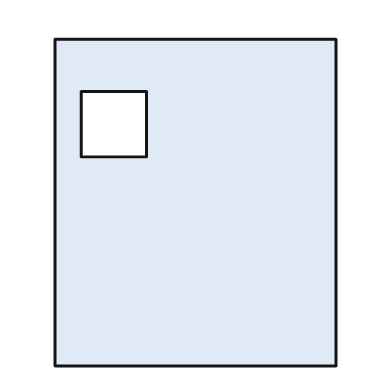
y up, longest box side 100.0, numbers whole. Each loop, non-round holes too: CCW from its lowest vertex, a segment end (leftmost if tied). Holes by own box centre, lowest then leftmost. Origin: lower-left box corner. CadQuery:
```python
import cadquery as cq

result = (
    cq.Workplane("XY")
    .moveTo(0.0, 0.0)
    .lineTo(86.0, 0.0)
    .lineTo(86.0, 100.0)
    .lineTo(0.0, 100.0)
    .close()
    .moveTo(8.0, 64.0)
    .lineTo(28.0, 64.0)
    .lineTo(28.0, 84.0)
    .lineTo(8.0, 84.0)
    .close()
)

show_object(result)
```